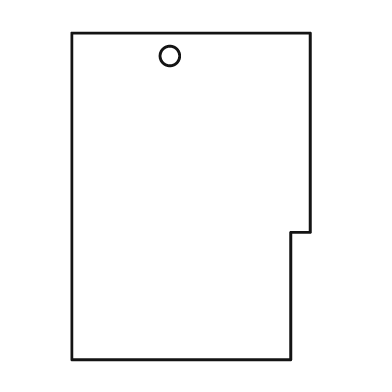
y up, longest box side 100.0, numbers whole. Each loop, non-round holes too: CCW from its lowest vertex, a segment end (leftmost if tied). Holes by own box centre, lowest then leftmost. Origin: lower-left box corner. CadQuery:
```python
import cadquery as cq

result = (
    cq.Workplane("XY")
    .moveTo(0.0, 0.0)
    .lineTo(67.0, 0.0)
    .lineTo(67.0, 39.0)
    .lineTo(73.0, 39.0)
    .lineTo(73.0, 100.0)
    .lineTo(0.0, 100.0)
    .close()
    .moveTo(30.0, 93.0)
    .circle(3.0)
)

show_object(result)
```